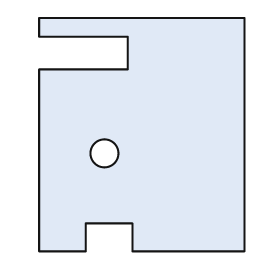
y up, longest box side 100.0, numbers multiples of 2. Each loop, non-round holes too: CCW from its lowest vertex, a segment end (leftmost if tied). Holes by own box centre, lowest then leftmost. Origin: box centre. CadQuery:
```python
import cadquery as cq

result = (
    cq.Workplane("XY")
    .moveTo(-44.0, -50.0)
    .lineTo(-24.0, -50.0)
    .lineTo(-24.0, -38.0)
    .lineTo(-4.0, -38.0)
    .lineTo(-4.0, -50.0)
    .lineTo(44.0, -50.0)
    .lineTo(44.0, 50.0)
    .lineTo(-44.0, 50.0)
    .lineTo(-44.0, 42.0)
    .lineTo(-6.0, 42.0)
    .lineTo(-6.0, 28.0)
    .lineTo(-44.0, 28.0)
    .close()
    .moveTo(-16.0, -8.0)
    .circle(6.0)
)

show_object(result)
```